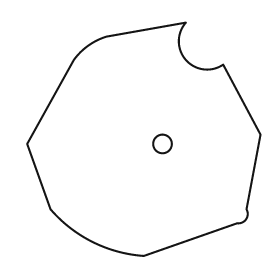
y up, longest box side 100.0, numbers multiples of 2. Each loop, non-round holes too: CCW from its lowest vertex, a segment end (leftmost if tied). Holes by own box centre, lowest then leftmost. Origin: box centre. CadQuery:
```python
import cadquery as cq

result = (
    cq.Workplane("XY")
    .moveTo(0.0, -50.0)
    .lineTo(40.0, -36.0)
    .threePointArc((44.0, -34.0), (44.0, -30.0))
    .lineTo(50.0, 2.0)
    .lineTo(34.0, 32.0)
    .threePointArc((18.0, 34.0), (18.0, 50.0))
    .lineTo(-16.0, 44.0)
    .threePointArc((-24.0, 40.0), (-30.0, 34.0))
    .lineTo(-50.0, -2.0)
    .lineTo(-40.0, -30.0)
    .threePointArc((-22.0, -44.0), (0.0, -50.0))
    .close()
    .moveTo(8.0, -2.0)
    .circle(4.0)
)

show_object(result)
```